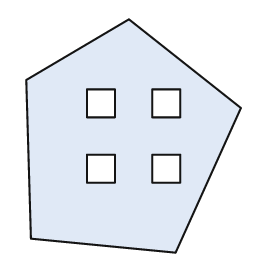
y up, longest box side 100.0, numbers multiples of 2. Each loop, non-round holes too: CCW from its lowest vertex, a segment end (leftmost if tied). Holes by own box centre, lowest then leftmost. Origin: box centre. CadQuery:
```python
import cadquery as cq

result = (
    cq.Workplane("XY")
    .moveTo(18.0, -50.0)
    .lineTo(46.0, 12.0)
    .lineTo(-2.0, 50.0)
    .lineTo(-46.0, 24.0)
    .lineTo(-44.0, -44.0)
    .close()
    .moveTo(-20.0, -20.0)
    .lineTo(-8.0, -20.0)
    .lineTo(-8.0, -8.0)
    .lineTo(-20.0, -8.0)
    .close()
    .moveTo(8.0, -20.0)
    .lineTo(20.0, -20.0)
    .lineTo(20.0, -8.0)
    .lineTo(8.0, -8.0)
    .close()
    .moveTo(-20.0, 8.0)
    .lineTo(-8.0, 8.0)
    .lineTo(-8.0, 20.0)
    .lineTo(-20.0, 20.0)
    .close()
    .moveTo(8.0, 8.0)
    .lineTo(20.0, 8.0)
    .lineTo(20.0, 20.0)
    .lineTo(8.0, 20.0)
    .close()
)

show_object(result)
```